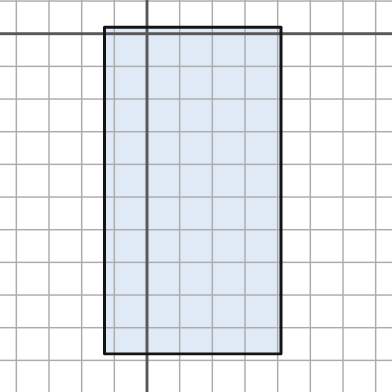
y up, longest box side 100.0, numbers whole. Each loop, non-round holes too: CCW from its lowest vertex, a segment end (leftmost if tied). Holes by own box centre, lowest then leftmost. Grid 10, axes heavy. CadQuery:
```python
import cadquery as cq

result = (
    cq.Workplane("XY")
    .moveTo(-13.0, -98.0)
    .lineTo(41.0, -98.0)
    .lineTo(41.0, 2.0)
    .lineTo(-13.0, 2.0)
    .close()
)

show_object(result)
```